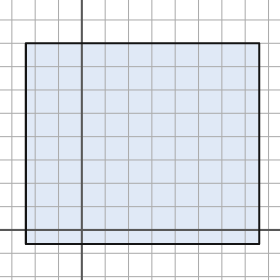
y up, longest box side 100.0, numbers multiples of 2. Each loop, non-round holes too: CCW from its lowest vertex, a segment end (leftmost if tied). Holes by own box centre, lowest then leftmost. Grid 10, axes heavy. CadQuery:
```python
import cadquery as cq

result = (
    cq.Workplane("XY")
    .moveTo(-24.0, -6.0)
    .lineTo(76.0, -6.0)
    .lineTo(76.0, 80.0)
    .lineTo(-24.0, 80.0)
    .close()
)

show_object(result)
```